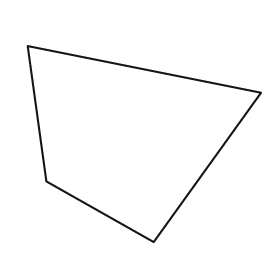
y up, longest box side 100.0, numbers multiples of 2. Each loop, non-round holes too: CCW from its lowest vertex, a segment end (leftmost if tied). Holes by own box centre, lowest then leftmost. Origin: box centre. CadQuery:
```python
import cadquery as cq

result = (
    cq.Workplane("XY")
    .moveTo(4.0, -42.0)
    .lineTo(50.0, 22.0)
    .lineTo(-50.0, 42.0)
    .lineTo(-42.0, -16.0)
    .close()
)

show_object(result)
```